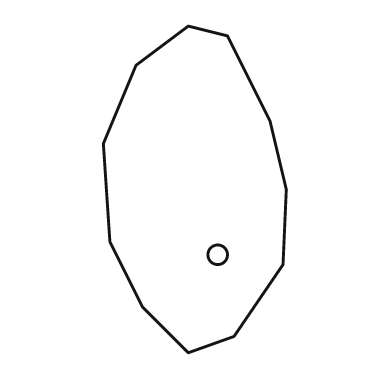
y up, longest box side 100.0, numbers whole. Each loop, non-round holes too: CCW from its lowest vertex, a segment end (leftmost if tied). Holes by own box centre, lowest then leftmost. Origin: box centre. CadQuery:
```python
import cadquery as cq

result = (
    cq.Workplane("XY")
    .moveTo(-2.0, -50.0)
    .lineTo(12.0, -45.0)
    .lineTo(27.0, -23.0)
    .lineTo(28.0, 0.0)
    .lineTo(23.0, 21.0)
    .lineTo(10.0, 47.0)
    .lineTo(-2.0, 50.0)
    .lineTo(-18.0, 38.0)
    .lineTo(-28.0, 14.0)
    .lineTo(-26.0, -16.0)
    .lineTo(-16.0, -36.0)
    .close()
    .moveTo(7.0, -20.0)
    .circle(3.0)
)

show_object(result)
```